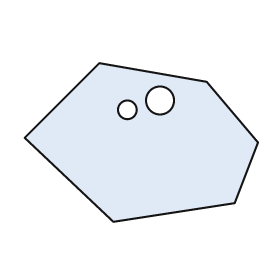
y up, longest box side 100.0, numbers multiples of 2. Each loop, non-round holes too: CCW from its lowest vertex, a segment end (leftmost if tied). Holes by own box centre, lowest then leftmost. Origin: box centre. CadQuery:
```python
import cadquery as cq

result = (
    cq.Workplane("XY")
    .moveTo(-12.0, -34.0)
    .lineTo(40.0, -26.0)
    .lineTo(50.0, 0.0)
    .lineTo(28.0, 26.0)
    .lineTo(-18.0, 34.0)
    .lineTo(-50.0, 2.0)
    .close()
    .moveTo(-6.0, 14.0)
    .circle(4.0)
    .moveTo(8.0, 18.0)
    .circle(6.0)
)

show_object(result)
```